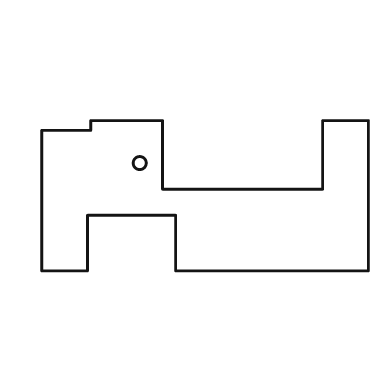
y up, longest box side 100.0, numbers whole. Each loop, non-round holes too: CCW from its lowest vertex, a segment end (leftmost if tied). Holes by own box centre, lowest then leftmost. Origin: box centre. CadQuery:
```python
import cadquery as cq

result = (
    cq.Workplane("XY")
    .moveTo(-50.0, -23.0)
    .lineTo(-36.0, -23.0)
    .lineTo(-36.0, -6.0)
    .lineTo(-9.0, -6.0)
    .lineTo(-9.0, -23.0)
    .lineTo(50.0, -23.0)
    .lineTo(50.0, 23.0)
    .lineTo(36.0, 23.0)
    .lineTo(36.0, 2.0)
    .lineTo(-13.0, 2.0)
    .lineTo(-13.0, 23.0)
    .lineTo(-35.0, 23.0)
    .lineTo(-35.0, 20.0)
    .lineTo(-50.0, 20.0)
    .close()
    .moveTo(-20.0, 10.0)
    .circle(2.0)
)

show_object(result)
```